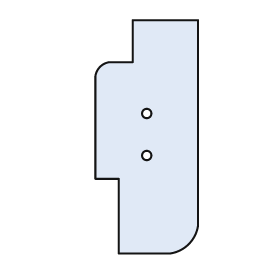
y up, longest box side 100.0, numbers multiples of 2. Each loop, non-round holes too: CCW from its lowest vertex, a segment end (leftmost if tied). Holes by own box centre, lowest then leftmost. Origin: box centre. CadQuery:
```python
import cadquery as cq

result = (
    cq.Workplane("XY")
    .moveTo(-12.0, -50.0)
    .lineTo(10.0, -50.0)
    .threePointArc((18.0, -46.0), (22.0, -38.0))
    .lineTo(22.0, 50.0)
    .lineTo(-6.0, 50.0)
    .lineTo(-6.0, 32.0)
    .lineTo(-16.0, 32.0)
    .threePointArc((-20.0, 30.0), (-22.0, 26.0))
    .lineTo(-22.0, -18.0)
    .lineTo(-12.0, -18.0)
    .close()
    .moveTo(0.0, -8.0)
    .circle(2.0)
    .moveTo(0.0, 10.0)
    .circle(2.0)
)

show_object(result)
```